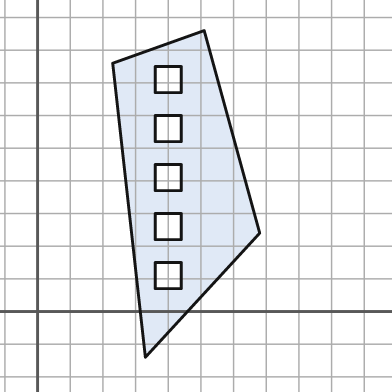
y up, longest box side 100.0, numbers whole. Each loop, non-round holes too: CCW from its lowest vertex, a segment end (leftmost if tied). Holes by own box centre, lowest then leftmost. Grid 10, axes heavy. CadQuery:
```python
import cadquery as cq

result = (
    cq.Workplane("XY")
    .moveTo(33.0, -14.0)
    .lineTo(68.0, 24.0)
    .lineTo(51.0, 86.0)
    .lineTo(23.0, 76.0)
    .close()
    .moveTo(36.0, 7.0)
    .lineTo(44.0, 7.0)
    .lineTo(44.0, 15.0)
    .lineTo(36.0, 15.0)
    .close()
    .moveTo(36.0, 22.0)
    .lineTo(44.0, 22.0)
    .lineTo(44.0, 30.0)
    .lineTo(36.0, 30.0)
    .close()
    .moveTo(36.0, 37.0)
    .lineTo(44.0, 37.0)
    .lineTo(44.0, 45.0)
    .lineTo(36.0, 45.0)
    .close()
    .moveTo(36.0, 52.0)
    .lineTo(44.0, 52.0)
    .lineTo(44.0, 60.0)
    .lineTo(36.0, 60.0)
    .close()
    .moveTo(36.0, 67.0)
    .lineTo(44.0, 67.0)
    .lineTo(44.0, 75.0)
    .lineTo(36.0, 75.0)
    .close()
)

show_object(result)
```